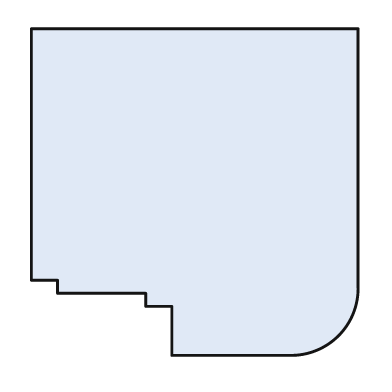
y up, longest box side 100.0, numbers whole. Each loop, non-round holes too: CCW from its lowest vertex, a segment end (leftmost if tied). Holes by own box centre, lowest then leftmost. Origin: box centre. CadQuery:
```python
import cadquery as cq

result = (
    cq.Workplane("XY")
    .moveTo(-7.0, -50.0)
    .lineTo(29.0, -50.0)
    .threePointArc((44.0, -44.0), (50.0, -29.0))
    .lineTo(50.0, 50.0)
    .lineTo(-50.0, 50.0)
    .lineTo(-50.0, -27.0)
    .lineTo(-42.0, -27.0)
    .lineTo(-42.0, -31.0)
    .lineTo(-15.0, -31.0)
    .lineTo(-15.0, -35.0)
    .lineTo(-7.0, -35.0)
    .close()
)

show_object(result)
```